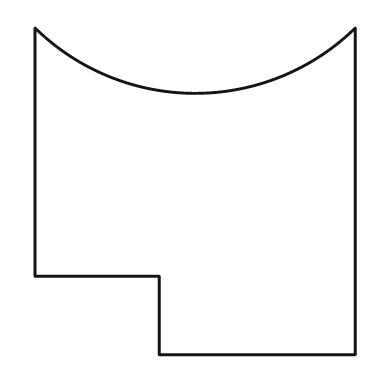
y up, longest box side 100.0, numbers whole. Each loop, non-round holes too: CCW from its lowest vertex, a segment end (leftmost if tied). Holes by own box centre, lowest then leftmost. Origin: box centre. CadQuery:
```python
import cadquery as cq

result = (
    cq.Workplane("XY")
    .moveTo(-11.0, -50.0)
    .lineTo(49.0, -50.0)
    .lineTo(49.0, 50.0)
    .threePointArc((0.0, 30.0), (-49.0, 50.0))
    .lineTo(-49.0, -26.0)
    .lineTo(-11.0, -26.0)
    .close()
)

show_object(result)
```